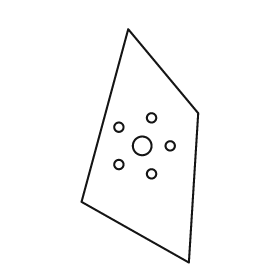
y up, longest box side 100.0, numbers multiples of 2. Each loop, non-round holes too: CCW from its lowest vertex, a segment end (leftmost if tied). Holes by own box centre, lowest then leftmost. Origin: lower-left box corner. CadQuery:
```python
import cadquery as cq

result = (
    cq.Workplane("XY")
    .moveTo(46.0, 0.0)
    .lineTo(50.0, 64.0)
    .lineTo(20.0, 100.0)
    .lineTo(0.0, 26.0)
    .close()
    .moveTo(30.0, 38.0)
    .circle(2.0)
    .moveTo(16.0, 42.0)
    .circle(2.0)
    .moveTo(26.0, 50.0)
    .circle(4.0)
    .moveTo(38.0, 50.0)
    .circle(2.0)
    .moveTo(16.0, 58.0)
    .circle(2.0)
    .moveTo(30.0, 62.0)
    .circle(2.0)
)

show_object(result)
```